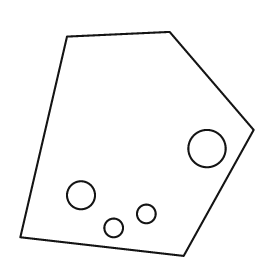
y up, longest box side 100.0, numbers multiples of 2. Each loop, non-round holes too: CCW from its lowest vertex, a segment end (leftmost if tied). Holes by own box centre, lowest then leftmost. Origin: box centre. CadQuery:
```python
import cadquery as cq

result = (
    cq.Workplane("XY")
    .moveTo(20.0, -48.0)
    .lineTo(50.0, 6.0)
    .lineTo(14.0, 48.0)
    .lineTo(-30.0, 46.0)
    .lineTo(-50.0, -40.0)
    .close()
    .moveTo(-10.0, -36.0)
    .circle(4.0)
    .moveTo(4.0, -30.0)
    .circle(4.0)
    .moveTo(-24.0, -22.0)
    .circle(6.0)
    .moveTo(30.0, -2.0)
    .circle(8.0)
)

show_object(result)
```